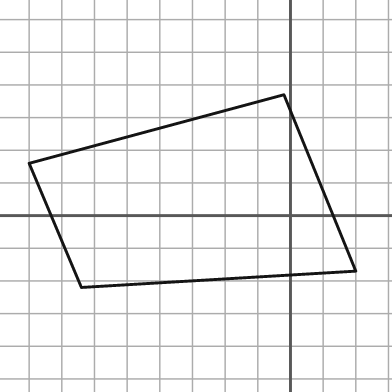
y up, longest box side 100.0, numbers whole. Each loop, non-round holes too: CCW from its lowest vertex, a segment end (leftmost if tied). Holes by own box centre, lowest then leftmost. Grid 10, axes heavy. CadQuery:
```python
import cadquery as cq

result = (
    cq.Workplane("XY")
    .moveTo(-64.0, -22.0)
    .lineTo(20.0, -17.0)
    .lineTo(-2.0, 37.0)
    .lineTo(-80.0, 16.0)
    .close()
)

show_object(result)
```